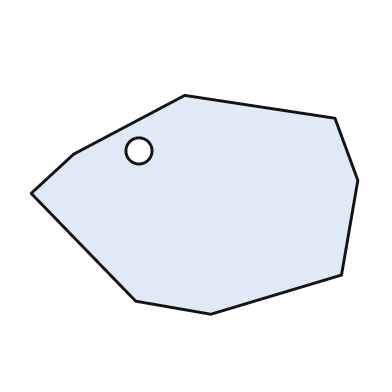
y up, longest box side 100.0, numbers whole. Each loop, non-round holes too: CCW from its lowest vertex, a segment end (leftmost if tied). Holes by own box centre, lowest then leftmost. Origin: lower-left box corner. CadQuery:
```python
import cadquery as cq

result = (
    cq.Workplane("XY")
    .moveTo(55.0, 0.0)
    .lineTo(95.0, 12.0)
    .lineTo(100.0, 41.0)
    .lineTo(93.0, 60.0)
    .lineTo(47.0, 67.0)
    .lineTo(13.0, 49.0)
    .lineTo(0.0, 37.0)
    .lineTo(32.0, 4.0)
    .close()
    .moveTo(33.0, 50.0)
    .circle(4.0)
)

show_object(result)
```